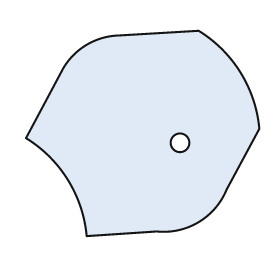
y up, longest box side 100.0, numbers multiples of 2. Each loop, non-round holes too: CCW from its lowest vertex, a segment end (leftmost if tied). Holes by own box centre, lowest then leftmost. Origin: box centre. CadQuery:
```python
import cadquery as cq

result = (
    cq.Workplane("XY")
    .moveTo(-24.0, -44.0)
    .lineTo(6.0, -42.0)
    .threePointArc((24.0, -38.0), (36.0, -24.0))
    .lineTo(50.0, 2.0)
    .threePointArc((42.0, 26.0), (24.0, 44.0))
    .lineTo(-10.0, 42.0)
    .threePointArc((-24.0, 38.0), (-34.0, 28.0))
    .lineTo(-50.0, -2.0)
    .threePointArc((-32.0, -20.0), (-24.0, -44.0))
    .close()
    .moveTo(16.0, -4.0)
    .circle(4.0)
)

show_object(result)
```